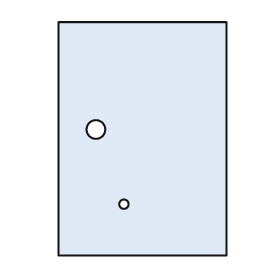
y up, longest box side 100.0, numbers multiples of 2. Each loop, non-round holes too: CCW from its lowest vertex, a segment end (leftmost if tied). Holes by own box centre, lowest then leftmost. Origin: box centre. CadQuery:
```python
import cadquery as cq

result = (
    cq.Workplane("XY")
    .moveTo(-36.0, -50.0)
    .lineTo(36.0, -50.0)
    .lineTo(36.0, 50.0)
    .lineTo(-36.0, 50.0)
    .close()
    .moveTo(-8.0, -28.0)
    .circle(2.0)
    .moveTo(-20.0, 4.0)
    .circle(4.0)
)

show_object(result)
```